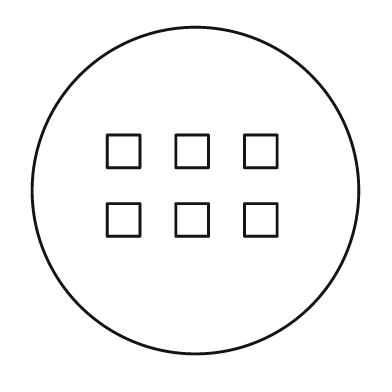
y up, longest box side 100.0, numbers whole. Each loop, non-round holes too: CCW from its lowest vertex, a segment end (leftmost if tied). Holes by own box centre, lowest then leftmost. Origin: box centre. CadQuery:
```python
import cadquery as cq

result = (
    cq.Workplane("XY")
    .moveTo(0.0, 0.0)
    .circle(50.0)
    .moveTo(-27.0, -14.0)
    .lineTo(-17.0, -14.0)
    .lineTo(-17.0, -4.0)
    .lineTo(-27.0, -4.0)
    .close()
    .moveTo(-6.0, -14.0)
    .lineTo(4.0, -14.0)
    .lineTo(4.0, -4.0)
    .lineTo(-6.0, -4.0)
    .close()
    .moveTo(15.0, -14.0)
    .lineTo(25.0, -14.0)
    .lineTo(25.0, -4.0)
    .lineTo(15.0, -4.0)
    .close()
    .moveTo(-27.0, 7.0)
    .lineTo(-17.0, 7.0)
    .lineTo(-17.0, 17.0)
    .lineTo(-27.0, 17.0)
    .close()
    .moveTo(-6.0, 7.0)
    .lineTo(4.0, 7.0)
    .lineTo(4.0, 17.0)
    .lineTo(-6.0, 17.0)
    .close()
    .moveTo(15.0, 7.0)
    .lineTo(25.0, 7.0)
    .lineTo(25.0, 17.0)
    .lineTo(15.0, 17.0)
    .close()
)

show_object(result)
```